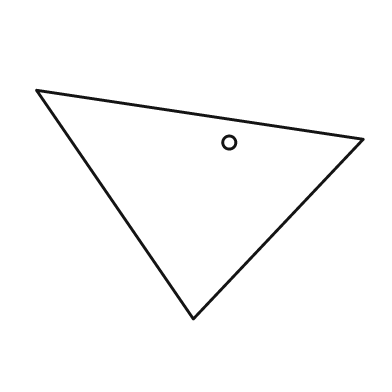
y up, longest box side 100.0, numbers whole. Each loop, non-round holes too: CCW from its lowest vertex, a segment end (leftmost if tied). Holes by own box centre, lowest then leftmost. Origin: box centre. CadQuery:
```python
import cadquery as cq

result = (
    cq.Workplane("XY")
    .moveTo(-2.0, -35.0)
    .lineTo(50.0, 20.0)
    .lineTo(-50.0, 35.0)
    .close()
    .moveTo(9.0, 19.0)
    .circle(2.0)
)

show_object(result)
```